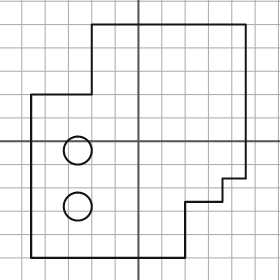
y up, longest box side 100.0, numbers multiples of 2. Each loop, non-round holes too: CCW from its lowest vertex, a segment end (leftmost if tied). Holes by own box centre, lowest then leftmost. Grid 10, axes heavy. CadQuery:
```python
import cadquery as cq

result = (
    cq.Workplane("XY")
    .moveTo(-46.0, -50.0)
    .lineTo(20.0, -50.0)
    .lineTo(20.0, -26.0)
    .lineTo(36.0, -26.0)
    .lineTo(36.0, -16.0)
    .lineTo(46.0, -16.0)
    .lineTo(46.0, 50.0)
    .lineTo(-20.0, 50.0)
    .lineTo(-20.0, 20.0)
    .lineTo(-46.0, 20.0)
    .close()
    .moveTo(-26.0, -28.0)
    .circle(6.0)
    .moveTo(-26.0, -4.0)
    .circle(6.0)
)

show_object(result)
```